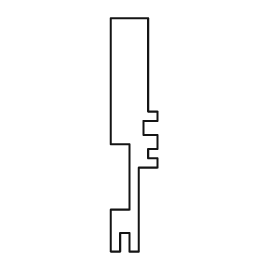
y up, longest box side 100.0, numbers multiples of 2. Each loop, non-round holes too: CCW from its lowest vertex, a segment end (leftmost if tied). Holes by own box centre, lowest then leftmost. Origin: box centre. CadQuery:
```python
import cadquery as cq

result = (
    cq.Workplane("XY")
    .moveTo(-10.0, -50.0)
    .lineTo(-6.0, -50.0)
    .lineTo(-6.0, -42.0)
    .lineTo(-2.0, -42.0)
    .lineTo(-2.0, -50.0)
    .lineTo(2.0, -50.0)
    .lineTo(2.0, -14.0)
    .lineTo(10.0, -14.0)
    .lineTo(10.0, -10.0)
    .lineTo(6.0, -10.0)
    .lineTo(6.0, -6.0)
    .lineTo(10.0, -6.0)
    .lineTo(10.0, 0.0)
    .lineTo(4.0, 0.0)
    .lineTo(4.0, 6.0)
    .lineTo(10.0, 6.0)
    .lineTo(10.0, 10.0)
    .lineTo(6.0, 10.0)
    .lineTo(6.0, 50.0)
    .lineTo(-10.0, 50.0)
    .lineTo(-10.0, -4.0)
    .lineTo(-2.0, -4.0)
    .lineTo(-2.0, -32.0)
    .lineTo(-10.0, -32.0)
    .close()
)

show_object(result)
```